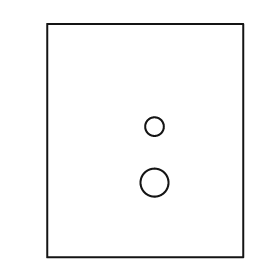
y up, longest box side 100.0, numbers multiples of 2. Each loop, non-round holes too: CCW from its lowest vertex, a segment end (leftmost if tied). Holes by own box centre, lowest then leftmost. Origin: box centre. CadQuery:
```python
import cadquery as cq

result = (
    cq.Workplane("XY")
    .moveTo(-42.0, -50.0)
    .lineTo(42.0, -50.0)
    .lineTo(42.0, 50.0)
    .lineTo(-42.0, 50.0)
    .close()
    .moveTo(4.0, -18.0)
    .circle(6.0)
    .moveTo(4.0, 6.0)
    .circle(4.0)
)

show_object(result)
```